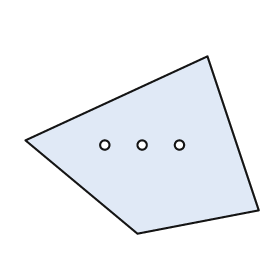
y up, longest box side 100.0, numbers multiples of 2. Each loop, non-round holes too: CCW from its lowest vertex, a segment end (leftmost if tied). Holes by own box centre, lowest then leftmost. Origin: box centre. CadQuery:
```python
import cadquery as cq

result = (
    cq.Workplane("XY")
    .moveTo(-2.0, -38.0)
    .lineTo(50.0, -28.0)
    .lineTo(28.0, 38.0)
    .lineTo(-50.0, 2.0)
    .close()
    .moveTo(-16.0, 0.0)
    .circle(2.0)
    .moveTo(0.0, 0.0)
    .circle(2.0)
    .moveTo(16.0, 0.0)
    .circle(2.0)
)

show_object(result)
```